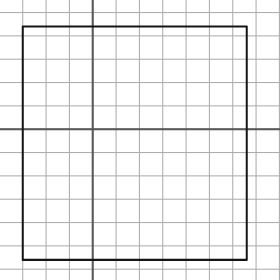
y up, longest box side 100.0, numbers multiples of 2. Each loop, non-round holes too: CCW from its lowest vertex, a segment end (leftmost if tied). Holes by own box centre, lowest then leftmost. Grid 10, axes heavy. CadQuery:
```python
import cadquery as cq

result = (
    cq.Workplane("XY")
    .moveTo(-30.0, -56.0)
    .lineTo(66.0, -56.0)
    .lineTo(66.0, 44.0)
    .lineTo(-30.0, 44.0)
    .close()
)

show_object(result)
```